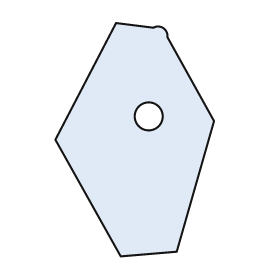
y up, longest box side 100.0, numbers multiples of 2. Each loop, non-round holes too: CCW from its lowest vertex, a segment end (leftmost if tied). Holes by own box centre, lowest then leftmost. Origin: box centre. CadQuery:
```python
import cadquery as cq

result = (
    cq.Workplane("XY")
    .moveTo(-6.0, -50.0)
    .lineTo(18.0, -48.0)
    .lineTo(34.0, 8.0)
    .lineTo(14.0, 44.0)
    .threePointArc((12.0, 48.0), (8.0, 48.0))
    .lineTo(-8.0, 50.0)
    .lineTo(-34.0, 0.0)
    .close()
    .moveTo(6.0, 10.0)
    .circle(6.0)
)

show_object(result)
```